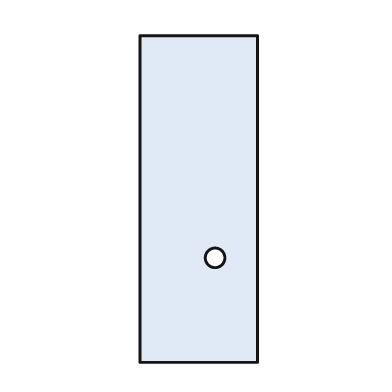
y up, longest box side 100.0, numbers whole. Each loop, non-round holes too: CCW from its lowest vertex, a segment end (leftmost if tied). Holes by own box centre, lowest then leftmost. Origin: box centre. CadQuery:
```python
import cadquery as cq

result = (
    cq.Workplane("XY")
    .moveTo(-18.0, -50.0)
    .lineTo(18.0, -50.0)
    .lineTo(18.0, 50.0)
    .lineTo(-18.0, 50.0)
    .close()
    .moveTo(5.0, -18.0)
    .circle(3.0)
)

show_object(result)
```